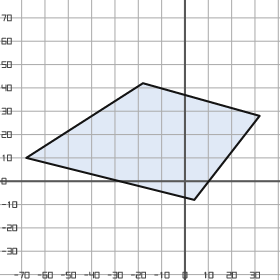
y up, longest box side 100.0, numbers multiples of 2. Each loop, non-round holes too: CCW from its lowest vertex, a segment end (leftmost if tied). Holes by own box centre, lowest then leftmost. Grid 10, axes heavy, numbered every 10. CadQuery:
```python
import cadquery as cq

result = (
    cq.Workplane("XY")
    .moveTo(4.0, -8.0)
    .lineTo(32.0, 28.0)
    .lineTo(-18.0, 42.0)
    .lineTo(-68.0, 10.0)
    .close()
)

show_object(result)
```